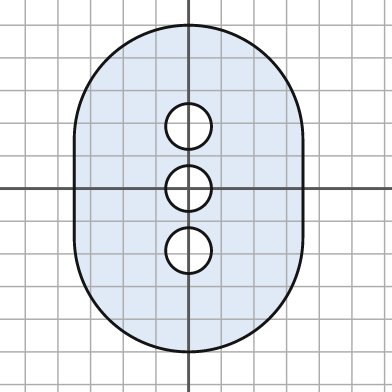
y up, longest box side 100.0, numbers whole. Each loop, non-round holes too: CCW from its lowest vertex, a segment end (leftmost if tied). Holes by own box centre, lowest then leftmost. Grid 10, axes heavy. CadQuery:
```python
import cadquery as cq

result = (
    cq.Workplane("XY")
    .moveTo(-35.0, -15.0)
    .threePointArc((0.0, -50.0), (35.0, -15.0))
    .lineTo(35.0, 15.0)
    .threePointArc((0.0, 50.0), (-35.0, 15.0))
    .close()
    .moveTo(0.0, -19.0)
    .circle(7.0)
    .moveTo(0.0, 0.0)
    .circle(7.0)
    .moveTo(0.0, 19.0)
    .circle(7.0)
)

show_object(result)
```